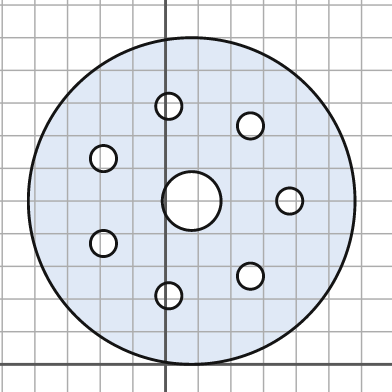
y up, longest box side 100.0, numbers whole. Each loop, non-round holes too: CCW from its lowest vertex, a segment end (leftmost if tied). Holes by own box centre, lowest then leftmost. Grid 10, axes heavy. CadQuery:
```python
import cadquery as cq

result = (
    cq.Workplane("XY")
    .moveTo(8.0, 50.0)
    .circle(50.0)
    .moveTo(1.0, 21.0)
    .circle(4.0)
    .moveTo(26.0, 27.0)
    .circle(4.0)
    .moveTo(-19.0, 37.0)
    .circle(4.0)
    .moveTo(8.0, 50.0)
    .circle(9.0)
    .moveTo(38.0, 50.0)
    .circle(4.0)
    .moveTo(-19.0, 63.0)
    .circle(4.0)
    .moveTo(26.0, 73.0)
    .circle(4.0)
    .moveTo(1.0, 79.0)
    .circle(4.0)
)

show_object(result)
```